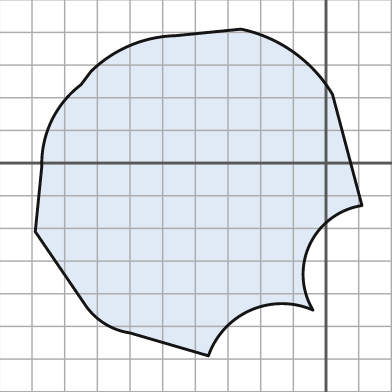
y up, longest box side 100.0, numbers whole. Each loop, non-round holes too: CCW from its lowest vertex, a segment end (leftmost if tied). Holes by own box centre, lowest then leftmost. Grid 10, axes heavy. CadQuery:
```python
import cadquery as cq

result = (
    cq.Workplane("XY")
    .moveTo(-36.0, -59.0)
    .threePointArc((-23.0, -45.0), (-4.0, -45.0))
    .threePointArc((-5.0, -25.0), (11.0, -13.0))
    .lineTo(2.0, 21.0)
    .threePointArc((-10.0, 34.0), (-26.0, 41.0))
    .lineTo(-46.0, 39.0)
    .threePointArc((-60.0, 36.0), (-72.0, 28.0))
    .lineTo(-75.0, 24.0)
    .threePointArc((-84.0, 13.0), (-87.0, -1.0))
    .lineTo(-89.0, -21.0)
    .lineTo(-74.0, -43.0)
    .threePointArc((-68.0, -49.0), (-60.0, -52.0))
    .close()
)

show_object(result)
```